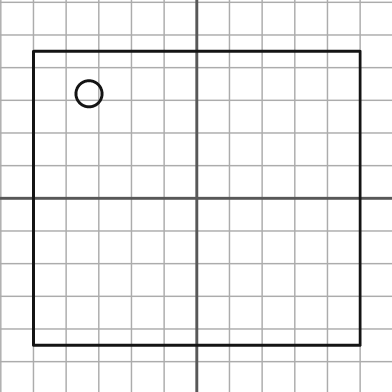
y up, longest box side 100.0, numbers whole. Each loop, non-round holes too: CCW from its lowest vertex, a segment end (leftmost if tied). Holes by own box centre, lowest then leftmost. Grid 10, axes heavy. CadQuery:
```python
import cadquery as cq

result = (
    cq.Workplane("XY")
    .moveTo(-50.0, -45.0)
    .lineTo(50.0, -45.0)
    .lineTo(50.0, 45.0)
    .lineTo(-50.0, 45.0)
    .close()
    .moveTo(-33.0, 32.0)
    .circle(4.0)
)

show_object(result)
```